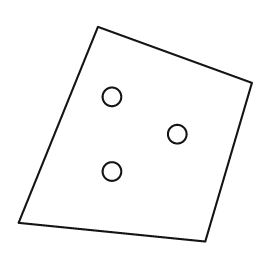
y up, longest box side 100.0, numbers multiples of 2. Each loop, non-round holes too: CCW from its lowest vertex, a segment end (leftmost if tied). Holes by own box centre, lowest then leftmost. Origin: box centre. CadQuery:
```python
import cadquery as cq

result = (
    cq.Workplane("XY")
    .moveTo(30.0, -46.0)
    .lineTo(50.0, 22.0)
    .lineTo(-16.0, 46.0)
    .lineTo(-50.0, -38.0)
    .close()
    .moveTo(-10.0, -16.0)
    .circle(4.0)
    .moveTo(18.0, 0.0)
    .circle(4.0)
    .moveTo(-10.0, 16.0)
    .circle(4.0)
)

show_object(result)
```